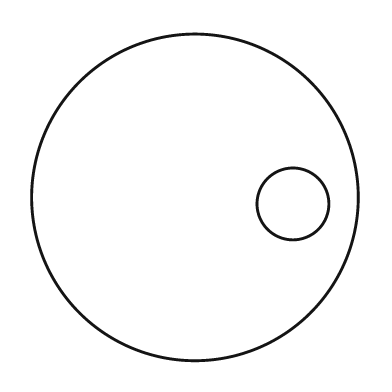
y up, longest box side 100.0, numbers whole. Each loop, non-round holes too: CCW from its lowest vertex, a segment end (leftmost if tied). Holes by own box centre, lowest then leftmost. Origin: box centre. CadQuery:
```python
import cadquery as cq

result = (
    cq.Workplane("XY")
    .moveTo(0.0, 0.0)
    .circle(50.0)
    .moveTo(30.0, -2.0)
    .circle(11.0)
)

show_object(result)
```